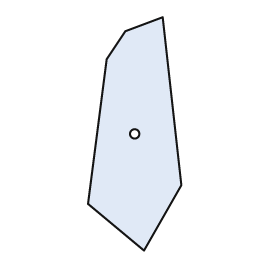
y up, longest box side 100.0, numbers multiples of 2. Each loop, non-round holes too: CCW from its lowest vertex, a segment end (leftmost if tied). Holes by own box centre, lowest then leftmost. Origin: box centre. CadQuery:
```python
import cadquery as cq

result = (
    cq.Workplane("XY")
    .moveTo(4.0, -50.0)
    .lineTo(20.0, -22.0)
    .lineTo(12.0, 50.0)
    .lineTo(-4.0, 44.0)
    .lineTo(-12.0, 32.0)
    .lineTo(-20.0, -30.0)
    .close()
    .moveTo(0.0, 0.0)
    .circle(2.0)
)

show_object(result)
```